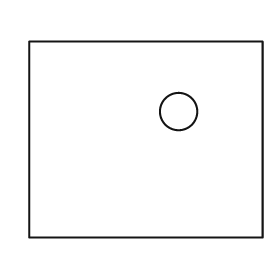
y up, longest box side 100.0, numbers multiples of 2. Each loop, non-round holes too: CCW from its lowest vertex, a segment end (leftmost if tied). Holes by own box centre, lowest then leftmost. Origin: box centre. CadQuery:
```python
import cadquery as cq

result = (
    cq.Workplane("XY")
    .moveTo(-50.0, -42.0)
    .lineTo(50.0, -42.0)
    .lineTo(50.0, 42.0)
    .lineTo(-50.0, 42.0)
    .close()
    .moveTo(14.0, 12.0)
    .circle(8.0)
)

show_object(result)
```